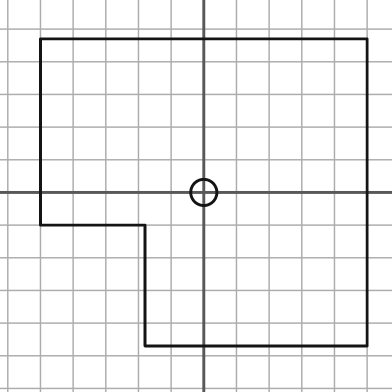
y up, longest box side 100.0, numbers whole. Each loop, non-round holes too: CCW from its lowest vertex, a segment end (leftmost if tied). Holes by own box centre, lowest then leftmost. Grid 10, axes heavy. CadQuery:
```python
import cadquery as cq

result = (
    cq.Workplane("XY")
    .moveTo(-18.0, -47.0)
    .lineTo(50.0, -47.0)
    .lineTo(50.0, 47.0)
    .lineTo(-50.0, 47.0)
    .lineTo(-50.0, -10.0)
    .lineTo(-18.0, -10.0)
    .close()
    .moveTo(0.0, 0.0)
    .circle(4.0)
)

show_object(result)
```